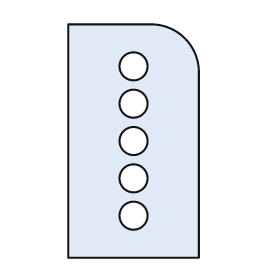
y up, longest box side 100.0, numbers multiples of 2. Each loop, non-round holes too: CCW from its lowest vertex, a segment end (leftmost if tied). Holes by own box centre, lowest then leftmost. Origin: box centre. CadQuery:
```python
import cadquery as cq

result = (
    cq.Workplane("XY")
    .moveTo(-28.0, -50.0)
    .lineTo(28.0, -50.0)
    .lineTo(28.0, 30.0)
    .threePointArc((22.0, 44.0), (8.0, 50.0))
    .lineTo(-28.0, 50.0)
    .close()
    .moveTo(0.0, -32.0)
    .circle(6.0)
    .moveTo(0.0, -16.0)
    .circle(6.0)
    .moveTo(0.0, 0.0)
    .circle(6.0)
    .moveTo(0.0, 16.0)
    .circle(6.0)
    .moveTo(0.0, 32.0)
    .circle(6.0)
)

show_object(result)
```